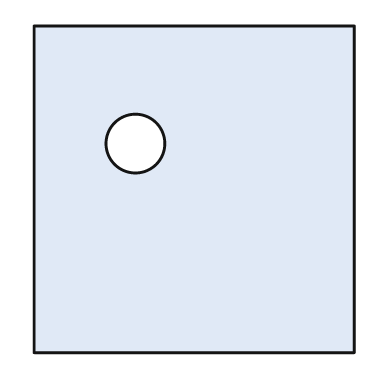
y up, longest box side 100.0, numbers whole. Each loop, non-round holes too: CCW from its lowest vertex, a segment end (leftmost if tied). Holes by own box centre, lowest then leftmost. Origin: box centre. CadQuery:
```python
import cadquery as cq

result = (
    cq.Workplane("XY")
    .moveTo(-49.0, -50.0)
    .lineTo(49.0, -50.0)
    .lineTo(49.0, 50.0)
    .lineTo(-49.0, 50.0)
    .close()
    .moveTo(-18.0, 14.0)
    .circle(9.0)
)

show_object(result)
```